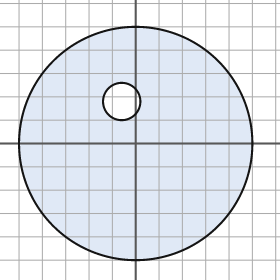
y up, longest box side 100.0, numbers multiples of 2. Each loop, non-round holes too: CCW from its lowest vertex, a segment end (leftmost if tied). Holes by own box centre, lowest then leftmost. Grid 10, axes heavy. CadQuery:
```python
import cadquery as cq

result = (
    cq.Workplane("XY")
    .moveTo(0.0, 0.0)
    .circle(50.0)
    .moveTo(-6.0, 18.0)
    .circle(8.0)
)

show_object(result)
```